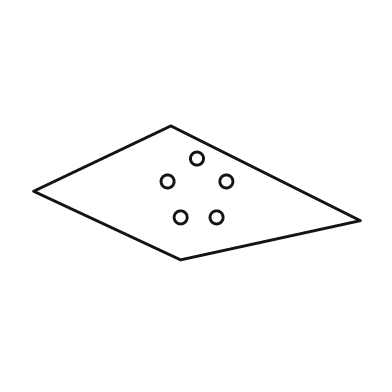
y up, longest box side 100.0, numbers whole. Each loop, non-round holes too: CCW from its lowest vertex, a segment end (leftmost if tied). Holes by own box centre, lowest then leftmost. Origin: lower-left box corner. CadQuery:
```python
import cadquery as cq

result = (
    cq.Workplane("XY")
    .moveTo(45.0, 0.0)
    .lineTo(100.0, 12.0)
    .lineTo(42.0, 41.0)
    .lineTo(0.0, 21.0)
    .close()
    .moveTo(45.0, 13.0)
    .circle(2.0)
    .moveTo(56.0, 13.0)
    .circle(2.0)
    .moveTo(41.0, 24.0)
    .circle(2.0)
    .moveTo(59.0, 24.0)
    .circle(2.0)
    .moveTo(50.0, 31.0)
    .circle(2.0)
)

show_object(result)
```